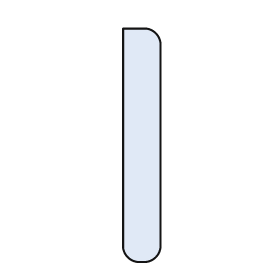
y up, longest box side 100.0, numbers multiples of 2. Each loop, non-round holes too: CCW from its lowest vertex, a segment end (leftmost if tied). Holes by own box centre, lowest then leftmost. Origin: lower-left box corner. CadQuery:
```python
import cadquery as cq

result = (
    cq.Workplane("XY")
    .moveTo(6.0, 0.0)
    .lineTo(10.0, 0.0)
    .threePointArc((14.0, 2.0), (16.0, 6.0))
    .lineTo(16.0, 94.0)
    .threePointArc((14.0, 98.0), (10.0, 100.0))
    .lineTo(0.0, 100.0)
    .lineTo(0.0, 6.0)
    .threePointArc((2.0, 2.0), (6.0, 0.0))
    .close()
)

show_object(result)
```